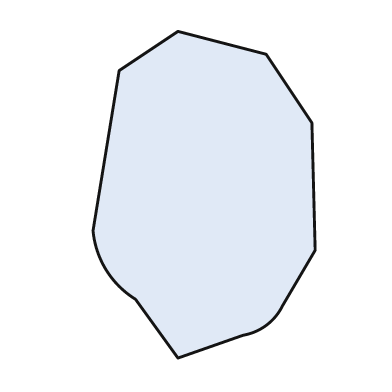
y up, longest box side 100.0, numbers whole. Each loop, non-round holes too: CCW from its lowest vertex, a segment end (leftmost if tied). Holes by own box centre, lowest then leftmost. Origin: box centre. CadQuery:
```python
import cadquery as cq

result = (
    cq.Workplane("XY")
    .moveTo(-8.0, -50.0)
    .lineTo(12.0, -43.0)
    .threePointArc((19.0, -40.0), (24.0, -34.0))
    .lineTo(34.0, -17.0)
    .lineTo(33.0, 22.0)
    .lineTo(19.0, 43.0)
    .lineTo(-8.0, 50.0)
    .lineTo(-26.0, 38.0)
    .lineTo(-34.0, -11.0)
    .threePointArc((-30.0, -23.0), (-21.0, -32.0))
    .close()
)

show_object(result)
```